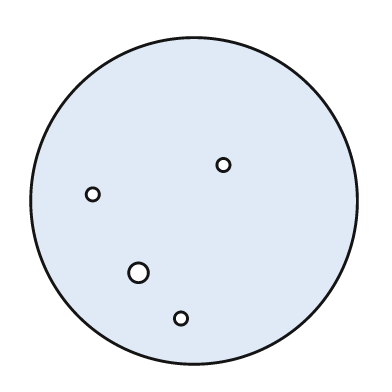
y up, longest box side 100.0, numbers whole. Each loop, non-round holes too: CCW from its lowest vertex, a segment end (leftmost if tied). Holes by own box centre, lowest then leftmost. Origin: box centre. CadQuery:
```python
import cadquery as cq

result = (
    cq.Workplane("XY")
    .moveTo(0.0, 0.0)
    .circle(50.0)
    .moveTo(-4.0, -36.0)
    .circle(2.0)
    .moveTo(-17.0, -22.0)
    .circle(3.0)
    .moveTo(-31.0, 2.0)
    .circle(2.0)
    .moveTo(9.0, 11.0)
    .circle(2.0)
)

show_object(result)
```